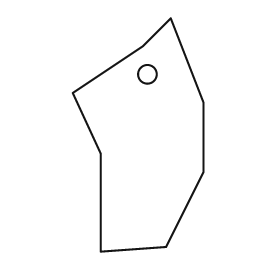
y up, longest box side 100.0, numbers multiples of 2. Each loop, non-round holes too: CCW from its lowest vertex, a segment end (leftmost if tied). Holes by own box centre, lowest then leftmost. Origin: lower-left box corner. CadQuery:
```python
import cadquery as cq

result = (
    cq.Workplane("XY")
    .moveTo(12.0, 0.0)
    .lineTo(40.0, 2.0)
    .lineTo(56.0, 34.0)
    .lineTo(56.0, 64.0)
    .lineTo(42.0, 100.0)
    .lineTo(30.0, 88.0)
    .lineTo(0.0, 68.0)
    .lineTo(12.0, 42.0)
    .close()
    .moveTo(32.0, 76.0)
    .circle(4.0)
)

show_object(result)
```